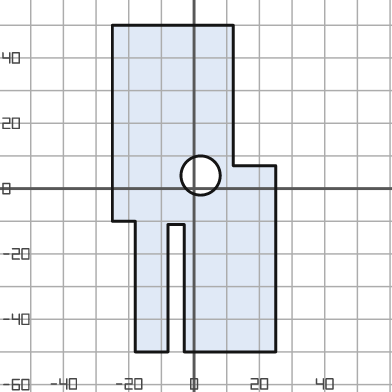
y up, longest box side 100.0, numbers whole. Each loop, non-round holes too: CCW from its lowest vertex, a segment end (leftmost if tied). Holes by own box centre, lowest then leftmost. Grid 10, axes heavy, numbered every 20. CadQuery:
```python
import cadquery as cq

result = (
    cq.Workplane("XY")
    .moveTo(-18.0, -50.0)
    .lineTo(-8.0, -50.0)
    .lineTo(-8.0, -11.0)
    .lineTo(-3.0, -11.0)
    .lineTo(-3.0, -50.0)
    .lineTo(25.0, -50.0)
    .lineTo(25.0, 7.0)
    .lineTo(12.0, 7.0)
    .lineTo(12.0, 50.0)
    .lineTo(-25.0, 50.0)
    .lineTo(-25.0, -10.0)
    .lineTo(-18.0, -10.0)
    .close()
    .moveTo(2.0, 4.0)
    .circle(6.0)
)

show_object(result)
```